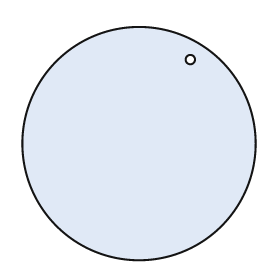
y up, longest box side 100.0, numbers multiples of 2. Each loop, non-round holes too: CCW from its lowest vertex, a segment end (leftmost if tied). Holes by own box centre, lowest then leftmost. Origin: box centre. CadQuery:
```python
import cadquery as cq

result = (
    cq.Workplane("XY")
    .moveTo(0.0, 0.0)
    .circle(50.0)
    .moveTo(22.0, 36.0)
    .circle(2.0)
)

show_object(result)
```